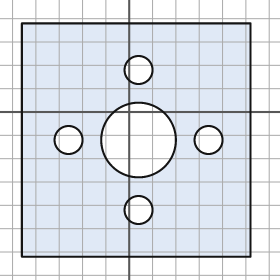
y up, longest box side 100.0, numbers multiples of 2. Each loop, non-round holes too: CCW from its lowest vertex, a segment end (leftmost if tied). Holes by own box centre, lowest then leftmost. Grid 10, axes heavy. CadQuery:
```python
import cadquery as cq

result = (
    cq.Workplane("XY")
    .moveTo(-46.0, -62.0)
    .lineTo(52.0, -62.0)
    .lineTo(52.0, 38.0)
    .lineTo(-46.0, 38.0)
    .close()
    .moveTo(4.0, -42.0)
    .circle(6.0)
    .moveTo(-26.0, -12.0)
    .circle(6.0)
    .moveTo(4.0, -12.0)
    .circle(16.0)
    .moveTo(34.0, -12.0)
    .circle(6.0)
    .moveTo(4.0, 18.0)
    .circle(6.0)
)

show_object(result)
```